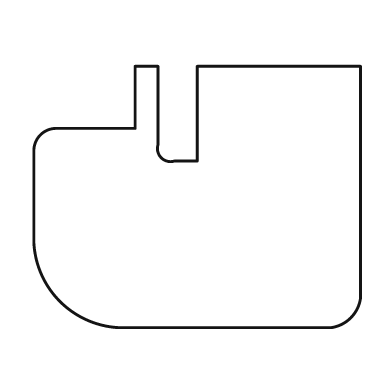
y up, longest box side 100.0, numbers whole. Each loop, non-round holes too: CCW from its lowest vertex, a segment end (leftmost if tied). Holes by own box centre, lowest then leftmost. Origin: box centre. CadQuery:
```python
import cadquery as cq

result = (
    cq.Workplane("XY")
    .moveTo(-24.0, -40.0)
    .lineTo(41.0, -40.0)
    .threePointArc((47.0, -37.0), (50.0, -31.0))
    .lineTo(50.0, 40.0)
    .lineTo(0.0, 40.0)
    .lineTo(0.0, 11.0)
    .lineTo(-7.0, 11.0)
    .threePointArc((-11.0, 12.0), (-12.0, 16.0))
    .lineTo(-12.0, 40.0)
    .lineTo(-19.0, 40.0)
    .lineTo(-19.0, 21.0)
    .lineTo(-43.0, 21.0)
    .threePointArc((-48.0, 19.0), (-50.0, 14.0))
    .lineTo(-50.0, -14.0)
    .threePointArc((-42.0, -32.0), (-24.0, -40.0))
    .close()
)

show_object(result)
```